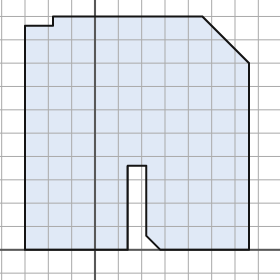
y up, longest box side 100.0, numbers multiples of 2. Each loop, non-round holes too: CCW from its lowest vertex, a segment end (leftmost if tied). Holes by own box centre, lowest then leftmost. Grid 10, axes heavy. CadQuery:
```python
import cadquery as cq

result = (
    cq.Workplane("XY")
    .moveTo(-30.0, 0.0)
    .lineTo(14.0, 0.0)
    .lineTo(14.0, 36.0)
    .lineTo(22.0, 36.0)
    .lineTo(22.0, 6.0)
    .lineTo(28.0, 0.0)
    .lineTo(66.0, 0.0)
    .lineTo(66.0, 80.0)
    .lineTo(46.0, 100.0)
    .lineTo(-18.0, 100.0)
    .lineTo(-18.0, 96.0)
    .lineTo(-30.0, 96.0)
    .close()
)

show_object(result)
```